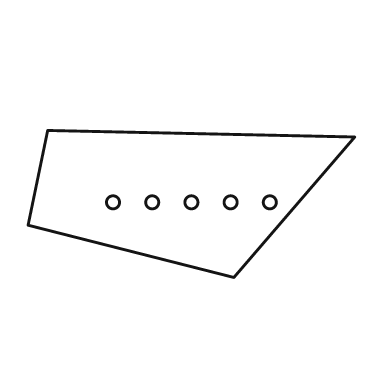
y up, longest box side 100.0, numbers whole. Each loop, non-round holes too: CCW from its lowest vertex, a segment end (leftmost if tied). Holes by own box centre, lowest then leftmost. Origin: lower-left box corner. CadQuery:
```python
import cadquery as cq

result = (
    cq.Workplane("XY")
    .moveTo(63.0, 0.0)
    .lineTo(100.0, 43.0)
    .lineTo(6.0, 45.0)
    .lineTo(0.0, 16.0)
    .close()
    .moveTo(26.0, 23.0)
    .circle(2.0)
    .moveTo(38.0, 23.0)
    .circle(2.0)
    .moveTo(50.0, 23.0)
    .circle(2.0)
    .moveTo(62.0, 23.0)
    .circle(2.0)
    .moveTo(74.0, 23.0)
    .circle(2.0)
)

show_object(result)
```